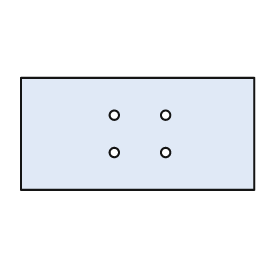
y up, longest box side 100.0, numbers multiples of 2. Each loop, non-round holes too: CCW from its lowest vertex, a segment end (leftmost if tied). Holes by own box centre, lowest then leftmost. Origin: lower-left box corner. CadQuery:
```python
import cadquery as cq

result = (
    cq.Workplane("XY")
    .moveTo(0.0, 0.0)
    .lineTo(100.0, 0.0)
    .lineTo(100.0, 48.0)
    .lineTo(0.0, 48.0)
    .close()
    .moveTo(40.0, 16.0)
    .circle(2.0)
    .moveTo(62.0, 16.0)
    .circle(2.0)
    .moveTo(40.0, 32.0)
    .circle(2.0)
    .moveTo(62.0, 32.0)
    .circle(2.0)
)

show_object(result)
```